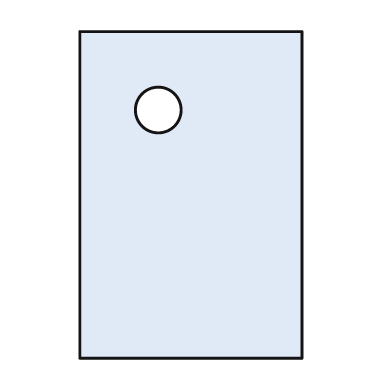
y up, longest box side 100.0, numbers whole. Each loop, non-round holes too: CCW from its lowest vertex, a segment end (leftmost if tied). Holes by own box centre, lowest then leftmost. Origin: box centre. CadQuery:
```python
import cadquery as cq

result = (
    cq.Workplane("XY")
    .moveTo(-34.0, -50.0)
    .lineTo(34.0, -50.0)
    .lineTo(34.0, 50.0)
    .lineTo(-34.0, 50.0)
    .close()
    .moveTo(-10.0, 26.0)
    .circle(7.0)
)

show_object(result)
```